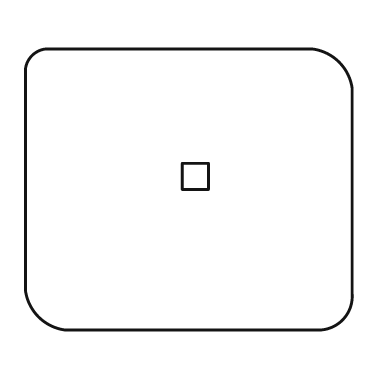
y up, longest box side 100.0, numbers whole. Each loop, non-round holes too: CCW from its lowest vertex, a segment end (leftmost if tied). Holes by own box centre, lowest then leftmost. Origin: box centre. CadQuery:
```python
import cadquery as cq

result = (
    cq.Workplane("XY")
    .moveTo(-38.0, -43.0)
    .lineTo(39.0, -43.0)
    .threePointArc((47.0, -40.0), (50.0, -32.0))
    .lineTo(50.0, 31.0)
    .threePointArc((46.0, 39.0), (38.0, 43.0))
    .lineTo(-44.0, 43.0)
    .threePointArc((-48.0, 41.0), (-50.0, 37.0))
    .lineTo(-50.0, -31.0)
    .threePointArc((-46.0, -39.0), (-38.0, -43.0))
    .close()
    .moveTo(-2.0, 0.0)
    .lineTo(6.0, 0.0)
    .lineTo(6.0, 8.0)
    .lineTo(-2.0, 8.0)
    .close()
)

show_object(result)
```